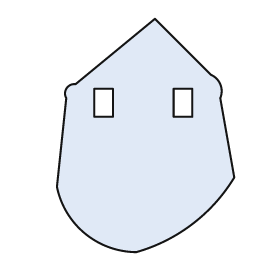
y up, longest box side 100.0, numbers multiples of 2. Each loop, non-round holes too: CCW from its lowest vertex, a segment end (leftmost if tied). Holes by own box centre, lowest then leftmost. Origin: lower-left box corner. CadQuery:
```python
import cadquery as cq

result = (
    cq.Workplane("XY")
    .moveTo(34.0, 0.0)
    .threePointArc((58.0, 12.0), (76.0, 32.0))
    .lineTo(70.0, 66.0)
    .threePointArc((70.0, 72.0), (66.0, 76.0))
    .lineTo(42.0, 100.0)
    .lineTo(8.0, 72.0)
    .threePointArc((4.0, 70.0), (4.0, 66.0))
    .lineTo(0.0, 28.0)
    .threePointArc((12.0, 8.0), (34.0, 0.0))
    .close()
    .moveTo(16.0, 58.0)
    .lineTo(24.0, 58.0)
    .lineTo(24.0, 70.0)
    .lineTo(16.0, 70.0)
    .close()
    .moveTo(50.0, 58.0)
    .lineTo(58.0, 58.0)
    .lineTo(58.0, 70.0)
    .lineTo(50.0, 70.0)
    .close()
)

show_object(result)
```